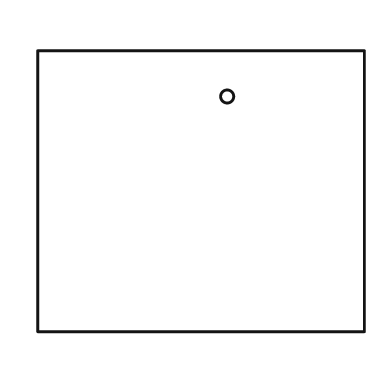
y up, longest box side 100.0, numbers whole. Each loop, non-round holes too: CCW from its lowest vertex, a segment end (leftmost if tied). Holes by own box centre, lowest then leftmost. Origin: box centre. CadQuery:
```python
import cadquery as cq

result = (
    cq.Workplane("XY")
    .moveTo(-50.0, -43.0)
    .lineTo(50.0, -43.0)
    .lineTo(50.0, 43.0)
    .lineTo(-50.0, 43.0)
    .close()
    .moveTo(8.0, 29.0)
    .circle(2.0)
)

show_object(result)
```